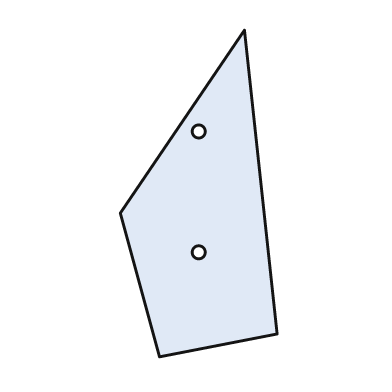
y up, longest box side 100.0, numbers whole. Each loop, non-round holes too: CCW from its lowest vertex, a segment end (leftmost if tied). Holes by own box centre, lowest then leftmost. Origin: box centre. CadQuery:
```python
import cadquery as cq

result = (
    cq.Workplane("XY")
    .moveTo(-12.0, -50.0)
    .lineTo(24.0, -43.0)
    .lineTo(14.0, 50.0)
    .lineTo(-24.0, -6.0)
    .close()
    .moveTo(0.0, -18.0)
    .circle(2.0)
    .moveTo(0.0, 19.0)
    .circle(2.0)
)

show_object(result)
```